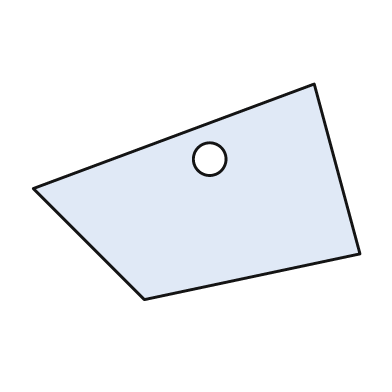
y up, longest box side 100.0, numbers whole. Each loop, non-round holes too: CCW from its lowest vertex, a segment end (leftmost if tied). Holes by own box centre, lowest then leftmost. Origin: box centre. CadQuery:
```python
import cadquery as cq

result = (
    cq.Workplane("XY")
    .moveTo(-16.0, -33.0)
    .lineTo(50.0, -19.0)
    .lineTo(36.0, 33.0)
    .lineTo(-50.0, 1.0)
    .close()
    .moveTo(4.0, 10.0)
    .circle(5.0)
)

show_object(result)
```